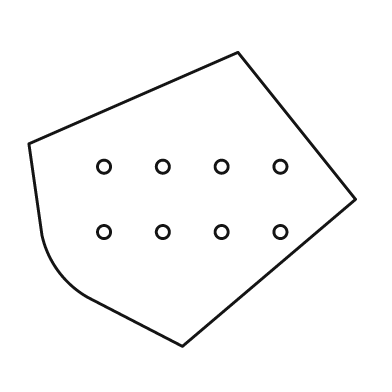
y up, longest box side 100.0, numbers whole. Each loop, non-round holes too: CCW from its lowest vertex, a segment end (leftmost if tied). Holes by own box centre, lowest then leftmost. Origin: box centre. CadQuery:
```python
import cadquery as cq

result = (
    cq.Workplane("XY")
    .moveTo(-3.0, -45.0)
    .lineTo(50.0, 0.0)
    .lineTo(14.0, 45.0)
    .lineTo(-50.0, 17.0)
    .lineTo(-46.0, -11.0)
    .threePointArc((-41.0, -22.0), (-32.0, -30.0))
    .close()
    .moveTo(-27.0, -10.0)
    .circle(2.0)
    .moveTo(-9.0, -10.0)
    .circle(2.0)
    .moveTo(9.0, -10.0)
    .circle(2.0)
    .moveTo(27.0, -10.0)
    .circle(2.0)
    .moveTo(-27.0, 10.0)
    .circle(2.0)
    .moveTo(-9.0, 10.0)
    .circle(2.0)
    .moveTo(9.0, 10.0)
    .circle(2.0)
    .moveTo(27.0, 10.0)
    .circle(2.0)
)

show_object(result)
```